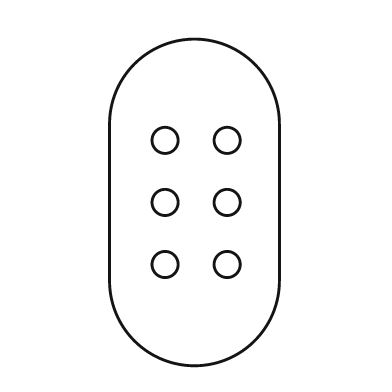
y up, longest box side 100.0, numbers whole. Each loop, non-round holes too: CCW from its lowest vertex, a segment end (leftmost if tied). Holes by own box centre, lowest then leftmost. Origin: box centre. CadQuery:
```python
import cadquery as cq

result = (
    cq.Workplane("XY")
    .moveTo(-26.0, -24.0)
    .threePointArc((0.0, -50.0), (26.0, -24.0))
    .lineTo(26.0, 24.0)
    .threePointArc((0.0, 50.0), (-26.0, 24.0))
    .close()
    .moveTo(-9.0, -19.0)
    .circle(4.0)
    .moveTo(10.0, -19.0)
    .circle(4.0)
    .moveTo(-9.0, 0.0)
    .circle(4.0)
    .moveTo(10.0, 0.0)
    .circle(4.0)
    .moveTo(-9.0, 19.0)
    .circle(4.0)
    .moveTo(10.0, 19.0)
    .circle(4.0)
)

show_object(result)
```